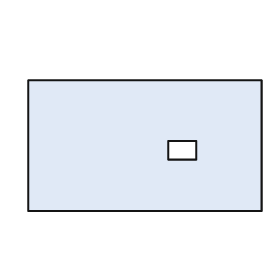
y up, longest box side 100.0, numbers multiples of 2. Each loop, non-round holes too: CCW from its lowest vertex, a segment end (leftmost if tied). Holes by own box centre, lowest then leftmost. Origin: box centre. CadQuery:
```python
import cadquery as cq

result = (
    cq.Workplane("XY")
    .moveTo(-50.0, -28.0)
    .lineTo(50.0, -28.0)
    .lineTo(50.0, 28.0)
    .lineTo(-50.0, 28.0)
    .close()
    .moveTo(10.0, -6.0)
    .lineTo(22.0, -6.0)
    .lineTo(22.0, 2.0)
    .lineTo(10.0, 2.0)
    .close()
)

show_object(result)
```